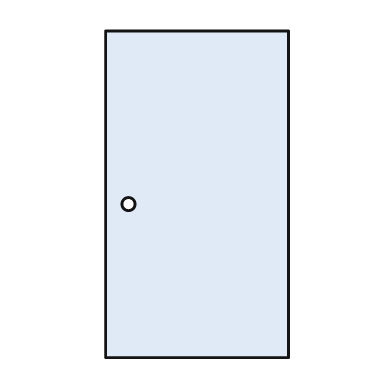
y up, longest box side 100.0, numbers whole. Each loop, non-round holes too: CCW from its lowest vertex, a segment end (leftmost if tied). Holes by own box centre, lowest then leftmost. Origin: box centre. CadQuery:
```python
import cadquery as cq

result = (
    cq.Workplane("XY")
    .moveTo(-28.0, -50.0)
    .lineTo(28.0, -50.0)
    .lineTo(28.0, 50.0)
    .lineTo(-28.0, 50.0)
    .close()
    .moveTo(-21.0, -3.0)
    .circle(2.0)
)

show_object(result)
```